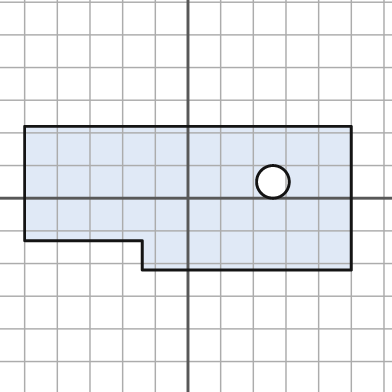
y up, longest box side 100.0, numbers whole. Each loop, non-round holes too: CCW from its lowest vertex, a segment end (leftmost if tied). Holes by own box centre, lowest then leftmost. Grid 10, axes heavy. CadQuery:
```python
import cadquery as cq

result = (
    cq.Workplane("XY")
    .moveTo(-14.0, -22.0)
    .lineTo(50.0, -22.0)
    .lineTo(50.0, 22.0)
    .lineTo(-50.0, 22.0)
    .lineTo(-50.0, -13.0)
    .lineTo(-14.0, -13.0)
    .close()
    .moveTo(26.0, 5.0)
    .circle(5.0)
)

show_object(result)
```